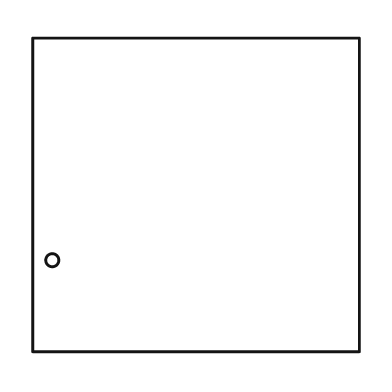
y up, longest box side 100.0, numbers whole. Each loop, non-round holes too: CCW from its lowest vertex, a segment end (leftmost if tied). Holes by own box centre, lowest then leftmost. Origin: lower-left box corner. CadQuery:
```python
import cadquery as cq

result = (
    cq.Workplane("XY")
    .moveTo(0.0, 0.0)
    .lineTo(100.0, 0.0)
    .lineTo(100.0, 96.0)
    .lineTo(0.0, 96.0)
    .close()
    .moveTo(6.0, 28.0)
    .circle(2.0)
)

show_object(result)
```